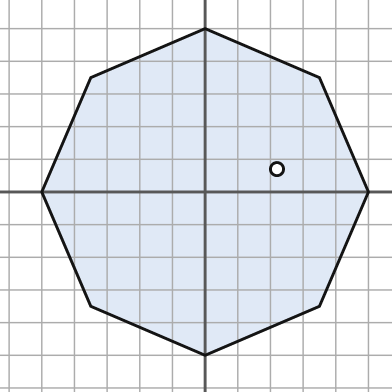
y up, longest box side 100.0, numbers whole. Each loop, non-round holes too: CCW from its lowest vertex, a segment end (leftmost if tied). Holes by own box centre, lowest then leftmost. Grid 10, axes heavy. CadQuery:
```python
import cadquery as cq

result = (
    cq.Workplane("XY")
    .moveTo(0.0, -50.0)
    .lineTo(35.0, -35.0)
    .lineTo(50.0, 0.0)
    .lineTo(35.0, 35.0)
    .lineTo(0.0, 50.0)
    .lineTo(-35.0, 35.0)
    .lineTo(-50.0, 0.0)
    .lineTo(-35.0, -35.0)
    .close()
    .moveTo(22.0, 7.0)
    .circle(2.0)
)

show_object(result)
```